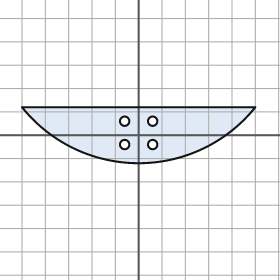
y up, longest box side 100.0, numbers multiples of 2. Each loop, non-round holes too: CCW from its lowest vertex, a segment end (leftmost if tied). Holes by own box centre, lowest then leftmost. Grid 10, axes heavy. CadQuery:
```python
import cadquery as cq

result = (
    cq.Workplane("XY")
    .moveTo(-50.0, 12.0)
    .threePointArc((0.0, -12.0), (50.0, 12.0))
    .close()
    .moveTo(-6.0, -4.0)
    .circle(2.0)
    .moveTo(6.0, -4.0)
    .circle(2.0)
    .moveTo(-6.0, 6.0)
    .circle(2.0)
    .moveTo(6.0, 6.0)
    .circle(2.0)
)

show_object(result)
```